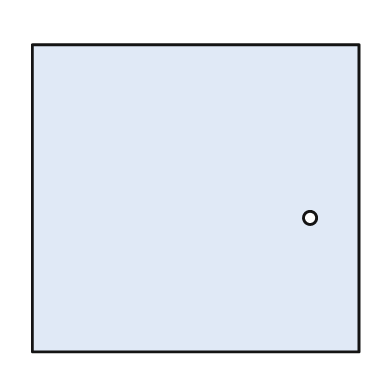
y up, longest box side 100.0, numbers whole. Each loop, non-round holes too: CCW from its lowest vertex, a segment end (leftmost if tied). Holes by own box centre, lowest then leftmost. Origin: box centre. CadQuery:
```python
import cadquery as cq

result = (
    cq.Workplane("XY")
    .moveTo(-50.0, -47.0)
    .lineTo(50.0, -47.0)
    .lineTo(50.0, 47.0)
    .lineTo(-50.0, 47.0)
    .close()
    .moveTo(35.0, -6.0)
    .circle(2.0)
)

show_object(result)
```